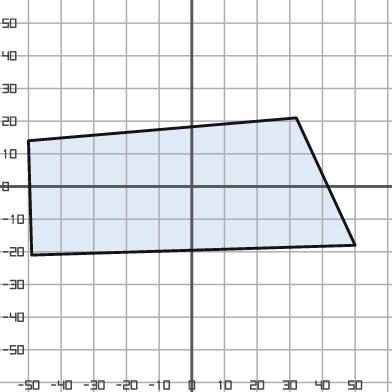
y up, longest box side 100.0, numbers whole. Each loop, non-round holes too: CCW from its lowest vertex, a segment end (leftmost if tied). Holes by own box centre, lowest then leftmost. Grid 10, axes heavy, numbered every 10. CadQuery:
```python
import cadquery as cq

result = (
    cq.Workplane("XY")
    .moveTo(-49.0, -21.0)
    .lineTo(50.0, -18.0)
    .lineTo(32.0, 21.0)
    .lineTo(-50.0, 14.0)
    .close()
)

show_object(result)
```